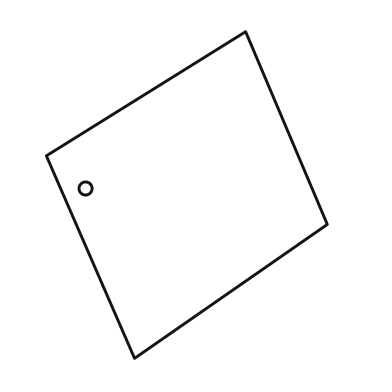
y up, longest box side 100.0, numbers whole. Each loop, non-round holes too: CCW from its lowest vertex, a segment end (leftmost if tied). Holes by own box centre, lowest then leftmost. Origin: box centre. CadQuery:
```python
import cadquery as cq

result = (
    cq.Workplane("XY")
    .moveTo(-16.0, -50.0)
    .lineTo(43.0, -9.0)
    .lineTo(18.0, 50.0)
    .lineTo(-43.0, 12.0)
    .close()
    .moveTo(-31.0, 2.0)
    .circle(2.0)
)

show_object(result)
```